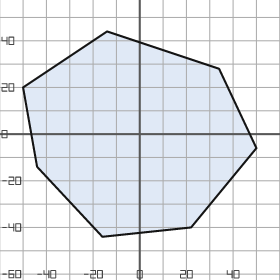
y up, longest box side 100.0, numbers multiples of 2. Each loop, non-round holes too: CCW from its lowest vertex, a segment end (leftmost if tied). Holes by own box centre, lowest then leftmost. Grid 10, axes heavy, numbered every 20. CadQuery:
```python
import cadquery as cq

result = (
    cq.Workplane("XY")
    .moveTo(-16.0, -44.0)
    .lineTo(22.0, -40.0)
    .lineTo(50.0, -6.0)
    .lineTo(34.0, 28.0)
    .lineTo(-14.0, 44.0)
    .lineTo(-50.0, 20.0)
    .lineTo(-44.0, -14.0)
    .close()
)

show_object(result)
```